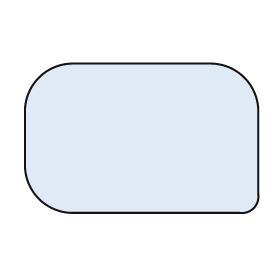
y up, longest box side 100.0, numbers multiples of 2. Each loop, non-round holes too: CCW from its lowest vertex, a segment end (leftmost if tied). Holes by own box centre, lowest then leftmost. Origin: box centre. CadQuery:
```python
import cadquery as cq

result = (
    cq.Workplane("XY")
    .moveTo(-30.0, -32.0)
    .lineTo(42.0, -32.0)
    .threePointArc((48.0, -30.0), (50.0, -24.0))
    .lineTo(50.0, 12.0)
    .threePointArc((44.0, 26.0), (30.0, 32.0))
    .lineTo(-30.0, 32.0)
    .threePointArc((-44.0, 26.0), (-50.0, 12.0))
    .lineTo(-50.0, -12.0)
    .threePointArc((-44.0, -26.0), (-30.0, -32.0))
    .close()
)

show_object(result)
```